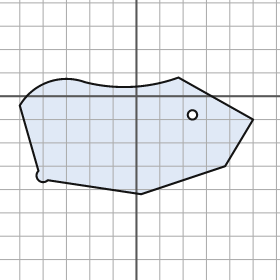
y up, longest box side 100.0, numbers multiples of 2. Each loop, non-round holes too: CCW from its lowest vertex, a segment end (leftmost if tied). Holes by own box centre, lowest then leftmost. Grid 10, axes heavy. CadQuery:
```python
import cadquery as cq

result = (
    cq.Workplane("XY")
    .moveTo(2.0, -42.0)
    .lineTo(38.0, -30.0)
    .lineTo(50.0, -10.0)
    .lineTo(18.0, 8.0)
    .threePointArc((-2.0, 4.0), (-22.0, 6.0))
    .threePointArc((-38.0, 6.0), (-50.0, -4.0))
    .lineTo(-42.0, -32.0)
    .threePointArc((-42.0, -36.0), (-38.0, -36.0))
    .close()
    .moveTo(24.0, -8.0)
    .circle(2.0)
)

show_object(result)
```